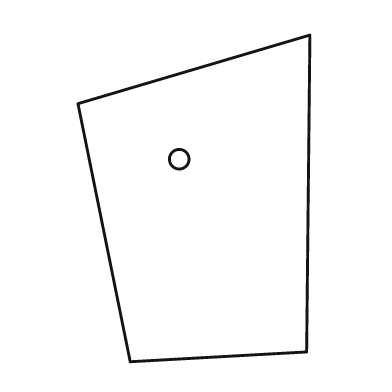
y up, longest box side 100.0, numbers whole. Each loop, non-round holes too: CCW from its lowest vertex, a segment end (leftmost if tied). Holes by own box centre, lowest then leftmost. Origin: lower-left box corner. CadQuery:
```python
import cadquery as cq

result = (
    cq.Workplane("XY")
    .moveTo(16.0, 0.0)
    .lineTo(70.0, 3.0)
    .lineTo(71.0, 100.0)
    .lineTo(0.0, 79.0)
    .close()
    .moveTo(31.0, 62.0)
    .circle(3.0)
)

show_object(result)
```